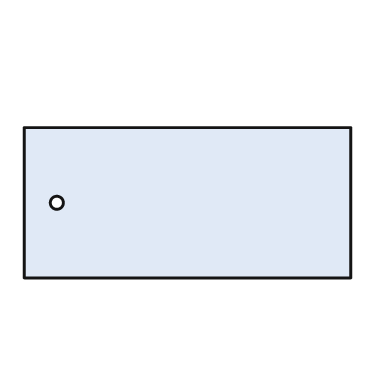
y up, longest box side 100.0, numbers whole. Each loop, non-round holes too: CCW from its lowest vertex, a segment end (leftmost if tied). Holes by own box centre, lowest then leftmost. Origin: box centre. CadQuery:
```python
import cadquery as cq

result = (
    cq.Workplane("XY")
    .moveTo(-50.0, -23.0)
    .lineTo(50.0, -23.0)
    .lineTo(50.0, 23.0)
    .lineTo(-50.0, 23.0)
    .close()
    .moveTo(-40.0, 0.0)
    .circle(2.0)
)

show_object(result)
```